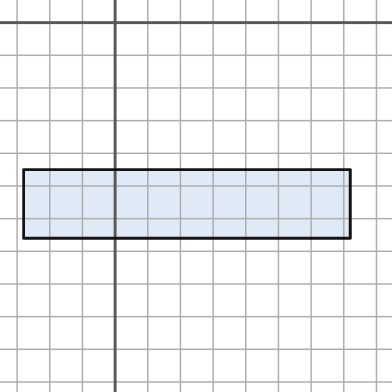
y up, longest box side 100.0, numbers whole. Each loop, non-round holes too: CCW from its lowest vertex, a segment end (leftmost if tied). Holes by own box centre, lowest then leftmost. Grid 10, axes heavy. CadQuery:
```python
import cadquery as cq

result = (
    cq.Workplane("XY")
    .moveTo(-28.0, -66.0)
    .lineTo(72.0, -66.0)
    .lineTo(72.0, -45.0)
    .lineTo(-28.0, -45.0)
    .close()
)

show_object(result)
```